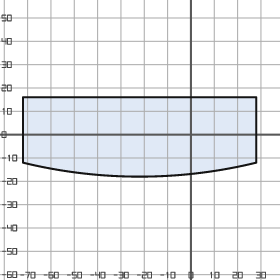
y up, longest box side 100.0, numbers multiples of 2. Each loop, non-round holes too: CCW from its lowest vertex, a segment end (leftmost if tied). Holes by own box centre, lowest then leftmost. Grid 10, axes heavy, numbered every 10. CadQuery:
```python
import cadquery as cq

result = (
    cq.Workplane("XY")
    .moveTo(-72.0, -12.0)
    .threePointArc((-22.0, -18.0), (28.0, -12.0))
    .lineTo(28.0, 16.0)
    .lineTo(-72.0, 16.0)
    .close()
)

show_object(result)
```